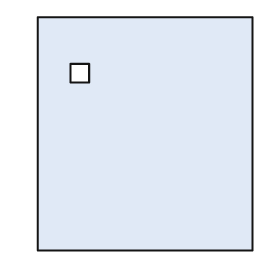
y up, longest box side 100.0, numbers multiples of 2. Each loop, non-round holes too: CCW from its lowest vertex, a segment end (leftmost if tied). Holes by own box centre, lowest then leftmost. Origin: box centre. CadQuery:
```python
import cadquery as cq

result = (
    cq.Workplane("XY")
    .moveTo(-46.0, -50.0)
    .lineTo(46.0, -50.0)
    .lineTo(46.0, 50.0)
    .lineTo(-46.0, 50.0)
    .close()
    .moveTo(-32.0, 22.0)
    .lineTo(-24.0, 22.0)
    .lineTo(-24.0, 30.0)
    .lineTo(-32.0, 30.0)
    .close()
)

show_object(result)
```